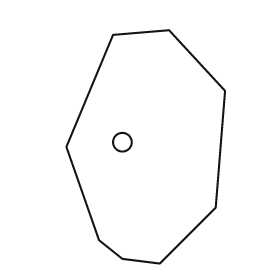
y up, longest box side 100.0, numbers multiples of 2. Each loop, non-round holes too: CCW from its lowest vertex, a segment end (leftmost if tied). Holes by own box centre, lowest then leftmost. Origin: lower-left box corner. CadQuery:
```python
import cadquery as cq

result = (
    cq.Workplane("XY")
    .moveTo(40.0, 0.0)
    .lineTo(64.0, 24.0)
    .lineTo(68.0, 74.0)
    .lineTo(44.0, 100.0)
    .lineTo(20.0, 98.0)
    .lineTo(0.0, 50.0)
    .lineTo(14.0, 10.0)
    .lineTo(24.0, 2.0)
    .close()
    .moveTo(24.0, 52.0)
    .circle(4.0)
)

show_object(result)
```